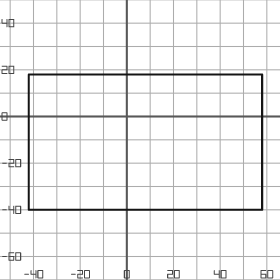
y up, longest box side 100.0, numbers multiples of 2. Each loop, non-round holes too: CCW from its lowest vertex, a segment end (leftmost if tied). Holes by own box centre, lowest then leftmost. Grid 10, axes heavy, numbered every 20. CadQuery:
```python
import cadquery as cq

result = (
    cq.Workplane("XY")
    .moveTo(-42.0, -40.0)
    .lineTo(58.0, -40.0)
    .lineTo(58.0, 18.0)
    .lineTo(-42.0, 18.0)
    .close()
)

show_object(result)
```